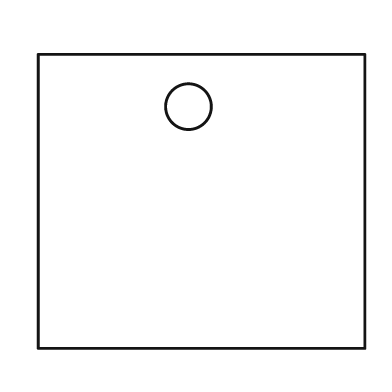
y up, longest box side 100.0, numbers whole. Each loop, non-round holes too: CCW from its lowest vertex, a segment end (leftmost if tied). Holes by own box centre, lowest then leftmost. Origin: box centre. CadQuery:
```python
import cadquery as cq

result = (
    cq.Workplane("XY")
    .moveTo(-50.0, -45.0)
    .lineTo(50.0, -45.0)
    .lineTo(50.0, 45.0)
    .lineTo(-50.0, 45.0)
    .close()
    .moveTo(-4.0, 29.0)
    .circle(7.0)
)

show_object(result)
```